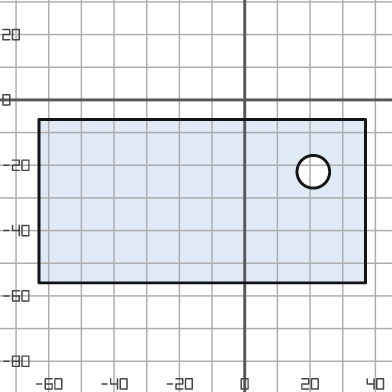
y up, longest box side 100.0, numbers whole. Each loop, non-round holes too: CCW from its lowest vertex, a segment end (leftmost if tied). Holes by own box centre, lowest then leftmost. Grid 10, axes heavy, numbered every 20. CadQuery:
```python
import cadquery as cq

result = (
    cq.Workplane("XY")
    .moveTo(-63.0, -56.0)
    .lineTo(37.0, -56.0)
    .lineTo(37.0, -6.0)
    .lineTo(-63.0, -6.0)
    .close()
    .moveTo(21.0, -22.0)
    .circle(5.0)
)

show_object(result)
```